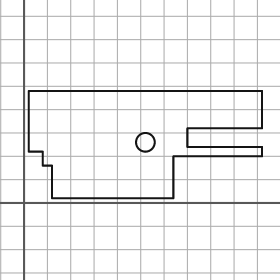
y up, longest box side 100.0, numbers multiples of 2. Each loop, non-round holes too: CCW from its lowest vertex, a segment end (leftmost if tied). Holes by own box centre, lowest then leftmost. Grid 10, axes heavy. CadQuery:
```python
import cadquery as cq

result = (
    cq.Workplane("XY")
    .moveTo(12.0, 2.0)
    .lineTo(64.0, 2.0)
    .lineTo(64.0, 20.0)
    .lineTo(102.0, 20.0)
    .lineTo(102.0, 24.0)
    .lineTo(70.0, 24.0)
    .lineTo(70.0, 32.0)
    .lineTo(102.0, 32.0)
    .lineTo(102.0, 48.0)
    .lineTo(2.0, 48.0)
    .lineTo(2.0, 22.0)
    .lineTo(8.0, 22.0)
    .lineTo(8.0, 16.0)
    .lineTo(12.0, 16.0)
    .close()
    .moveTo(52.0, 26.0)
    .circle(4.0)
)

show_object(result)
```